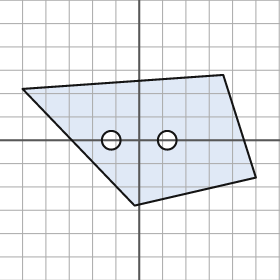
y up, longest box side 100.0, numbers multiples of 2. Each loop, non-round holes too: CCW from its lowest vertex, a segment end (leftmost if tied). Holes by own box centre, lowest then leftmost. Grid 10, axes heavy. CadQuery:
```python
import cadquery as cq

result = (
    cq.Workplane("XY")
    .moveTo(-2.0, -28.0)
    .lineTo(50.0, -16.0)
    .lineTo(36.0, 28.0)
    .lineTo(-50.0, 22.0)
    .close()
    .moveTo(-12.0, 0.0)
    .circle(4.0)
    .moveTo(12.0, 0.0)
    .circle(4.0)
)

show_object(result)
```